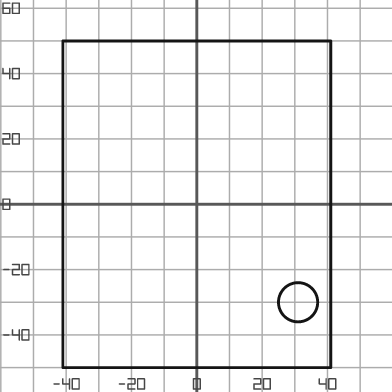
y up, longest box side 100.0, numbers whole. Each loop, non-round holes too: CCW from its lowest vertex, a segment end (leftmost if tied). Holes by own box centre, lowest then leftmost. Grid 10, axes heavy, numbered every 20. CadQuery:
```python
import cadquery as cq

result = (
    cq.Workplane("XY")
    .moveTo(-41.0, -50.0)
    .lineTo(41.0, -50.0)
    .lineTo(41.0, 50.0)
    .lineTo(-41.0, 50.0)
    .close()
    .moveTo(31.0, -30.0)
    .circle(6.0)
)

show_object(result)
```